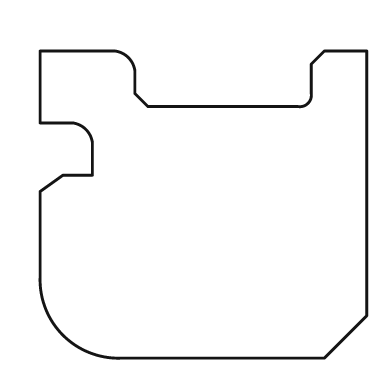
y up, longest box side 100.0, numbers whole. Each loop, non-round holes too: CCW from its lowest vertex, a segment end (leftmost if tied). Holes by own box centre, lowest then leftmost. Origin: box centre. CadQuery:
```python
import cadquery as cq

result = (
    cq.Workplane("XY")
    .moveTo(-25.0, -47.0)
    .lineTo(37.0, -47.0)
    .lineTo(50.0, -34.0)
    .lineTo(50.0, 47.0)
    .lineTo(37.0, 47.0)
    .lineTo(33.0, 43.0)
    .lineTo(33.0, 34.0)
    .threePointArc((32.0, 31.0), (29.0, 30.0))
    .lineTo(-17.0, 30.0)
    .lineTo(-21.0, 34.0)
    .lineTo(-21.0, 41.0)
    .threePointArc((-23.0, 45.0), (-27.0, 47.0))
    .lineTo(-50.0, 47.0)
    .lineTo(-50.0, 25.0)
    .lineTo(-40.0, 25.0)
    .threePointArc((-36.0, 23.0), (-34.0, 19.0))
    .lineTo(-34.0, 9.0)
    .lineTo(-43.0, 9.0)
    .lineTo(-50.0, 4.0)
    .lineTo(-50.0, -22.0)
    .threePointArc((-43.0, -40.0), (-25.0, -47.0))
    .close()
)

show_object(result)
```